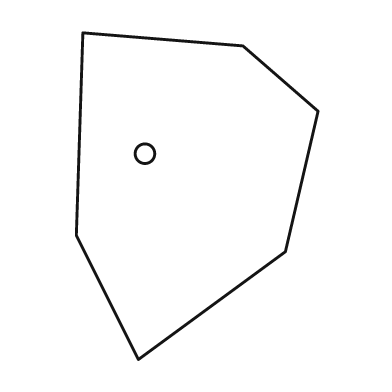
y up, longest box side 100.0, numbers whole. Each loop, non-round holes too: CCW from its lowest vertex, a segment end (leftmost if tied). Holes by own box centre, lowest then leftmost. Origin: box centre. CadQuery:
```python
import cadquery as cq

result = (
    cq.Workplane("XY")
    .moveTo(-18.0, -50.0)
    .lineTo(27.0, -17.0)
    .lineTo(37.0, 26.0)
    .lineTo(14.0, 46.0)
    .lineTo(-35.0, 50.0)
    .lineTo(-37.0, -12.0)
    .close()
    .moveTo(-16.0, 13.0)
    .circle(3.0)
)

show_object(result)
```